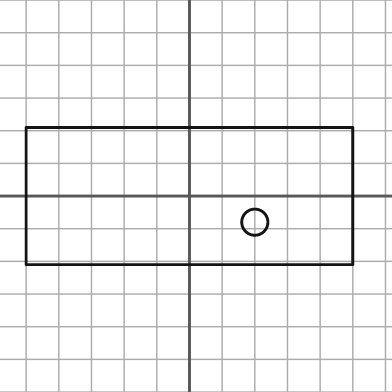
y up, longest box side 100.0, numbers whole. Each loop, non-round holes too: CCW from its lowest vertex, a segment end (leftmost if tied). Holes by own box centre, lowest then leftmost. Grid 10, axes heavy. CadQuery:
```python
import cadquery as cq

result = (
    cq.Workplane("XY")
    .moveTo(-50.0, -21.0)
    .lineTo(50.0, -21.0)
    .lineTo(50.0, 21.0)
    .lineTo(-50.0, 21.0)
    .close()
    .moveTo(20.0, -8.0)
    .circle(4.0)
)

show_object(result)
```